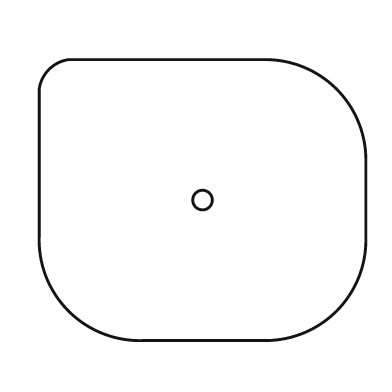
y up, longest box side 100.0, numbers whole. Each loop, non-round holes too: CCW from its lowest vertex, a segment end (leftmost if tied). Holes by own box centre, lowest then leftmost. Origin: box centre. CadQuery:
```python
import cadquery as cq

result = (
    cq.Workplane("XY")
    .moveTo(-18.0, -43.0)
    .lineTo(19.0, -43.0)
    .threePointArc((41.0, -34.0), (50.0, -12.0))
    .lineTo(50.0, 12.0)
    .threePointArc((41.0, 34.0), (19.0, 43.0))
    .lineTo(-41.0, 43.0)
    .threePointArc((-47.0, 40.0), (-50.0, 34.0))
    .lineTo(-50.0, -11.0)
    .threePointArc((-41.0, -34.0), (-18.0, -43.0))
    .close()
    .moveTo(0.0, 0.0)
    .circle(3.0)
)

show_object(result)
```